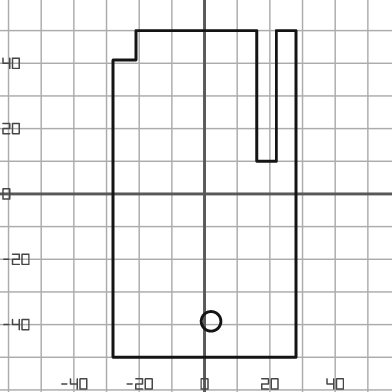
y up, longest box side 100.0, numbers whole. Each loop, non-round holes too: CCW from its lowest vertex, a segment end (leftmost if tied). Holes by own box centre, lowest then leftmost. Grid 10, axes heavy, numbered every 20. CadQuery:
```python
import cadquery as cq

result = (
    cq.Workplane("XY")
    .moveTo(-28.0, -50.0)
    .lineTo(28.0, -50.0)
    .lineTo(28.0, 50.0)
    .lineTo(22.0, 50.0)
    .lineTo(22.0, 10.0)
    .lineTo(16.0, 10.0)
    .lineTo(16.0, 50.0)
    .lineTo(-21.0, 50.0)
    .lineTo(-21.0, 41.0)
    .lineTo(-28.0, 41.0)
    .close()
    .moveTo(2.0, -39.0)
    .circle(3.0)
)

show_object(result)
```